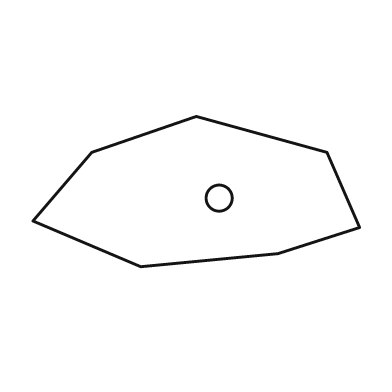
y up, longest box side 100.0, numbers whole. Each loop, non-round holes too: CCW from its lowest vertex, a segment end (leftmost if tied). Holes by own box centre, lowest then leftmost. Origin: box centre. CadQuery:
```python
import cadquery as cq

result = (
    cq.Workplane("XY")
    .moveTo(-17.0, -23.0)
    .lineTo(25.0, -19.0)
    .lineTo(50.0, -11.0)
    .lineTo(40.0, 12.0)
    .lineTo(0.0, 23.0)
    .lineTo(-32.0, 12.0)
    .lineTo(-50.0, -9.0)
    .close()
    .moveTo(7.0, -2.0)
    .circle(4.0)
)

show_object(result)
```